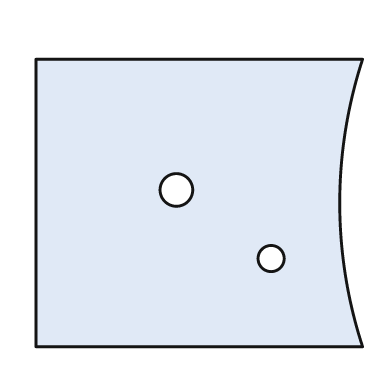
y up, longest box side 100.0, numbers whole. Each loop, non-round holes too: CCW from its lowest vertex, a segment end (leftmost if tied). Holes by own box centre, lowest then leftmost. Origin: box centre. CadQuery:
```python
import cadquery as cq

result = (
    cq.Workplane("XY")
    .moveTo(-50.0, -44.0)
    .lineTo(50.0, -44.0)
    .threePointArc((43.0, 0.0), (50.0, 44.0))
    .lineTo(-50.0, 44.0)
    .close()
    .moveTo(22.0, -17.0)
    .circle(4.0)
    .moveTo(-7.0, 4.0)
    .circle(5.0)
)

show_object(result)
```